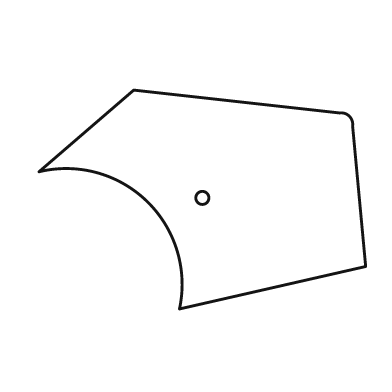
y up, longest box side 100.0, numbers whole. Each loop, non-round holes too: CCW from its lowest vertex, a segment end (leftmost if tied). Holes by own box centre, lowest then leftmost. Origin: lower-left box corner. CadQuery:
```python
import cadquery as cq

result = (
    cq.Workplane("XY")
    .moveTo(43.0, 0.0)
    .lineTo(100.0, 13.0)
    .lineTo(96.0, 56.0)
    .threePointArc((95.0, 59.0), (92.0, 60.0))
    .lineTo(29.0, 67.0)
    .lineTo(0.0, 42.0)
    .threePointArc((33.0, 33.0), (43.0, 0.0))
    .close()
    .moveTo(50.0, 34.0)
    .circle(2.0)
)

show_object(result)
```